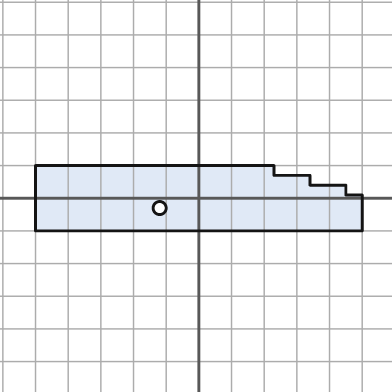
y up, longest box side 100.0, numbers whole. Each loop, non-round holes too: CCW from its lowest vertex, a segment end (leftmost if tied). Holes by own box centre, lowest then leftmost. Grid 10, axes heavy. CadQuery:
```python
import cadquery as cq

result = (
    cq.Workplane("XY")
    .moveTo(-50.0, -10.0)
    .lineTo(50.0, -10.0)
    .lineTo(50.0, 1.0)
    .lineTo(45.0, 1.0)
    .lineTo(45.0, 4.0)
    .lineTo(34.0, 4.0)
    .lineTo(34.0, 7.0)
    .lineTo(23.0, 7.0)
    .lineTo(23.0, 10.0)
    .lineTo(-50.0, 10.0)
    .close()
    .moveTo(-12.0, -3.0)
    .circle(2.0)
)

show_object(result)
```